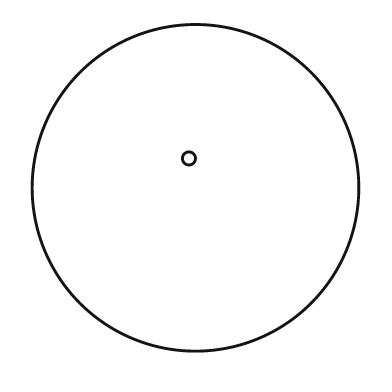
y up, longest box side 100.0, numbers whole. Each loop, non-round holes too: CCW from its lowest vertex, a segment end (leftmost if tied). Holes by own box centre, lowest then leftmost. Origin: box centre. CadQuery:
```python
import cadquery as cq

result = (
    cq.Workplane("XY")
    .moveTo(0.0, 0.0)
    .circle(50.0)
    .moveTo(-2.0, 9.0)
    .circle(2.0)
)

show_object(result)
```